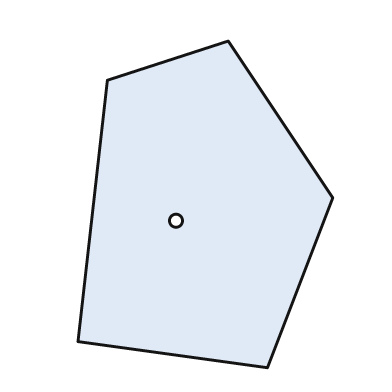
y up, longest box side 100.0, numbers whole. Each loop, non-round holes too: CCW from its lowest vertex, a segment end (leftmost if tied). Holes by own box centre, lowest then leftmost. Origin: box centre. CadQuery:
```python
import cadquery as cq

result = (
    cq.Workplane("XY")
    .moveTo(19.0, -50.0)
    .lineTo(39.0, 2.0)
    .lineTo(7.0, 50.0)
    .lineTo(-30.0, 38.0)
    .lineTo(-39.0, -42.0)
    .close()
    .moveTo(-9.0, -5.0)
    .circle(2.0)
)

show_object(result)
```